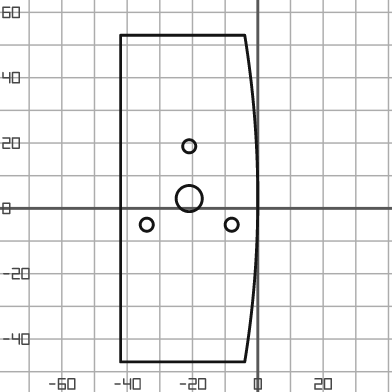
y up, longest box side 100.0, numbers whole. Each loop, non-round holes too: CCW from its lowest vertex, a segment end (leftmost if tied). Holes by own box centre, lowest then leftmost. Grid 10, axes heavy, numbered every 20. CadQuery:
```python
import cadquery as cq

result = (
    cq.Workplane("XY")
    .moveTo(-42.0, -47.0)
    .lineTo(-4.0, -47.0)
    .threePointArc((0.0, 3.0), (-4.0, 53.0))
    .lineTo(-42.0, 53.0)
    .close()
    .moveTo(-34.0, -5.0)
    .circle(2.0)
    .moveTo(-8.0, -5.0)
    .circle(2.0)
    .moveTo(-21.0, 3.0)
    .circle(4.0)
    .moveTo(-21.0, 19.0)
    .circle(2.0)
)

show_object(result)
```